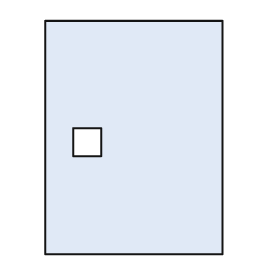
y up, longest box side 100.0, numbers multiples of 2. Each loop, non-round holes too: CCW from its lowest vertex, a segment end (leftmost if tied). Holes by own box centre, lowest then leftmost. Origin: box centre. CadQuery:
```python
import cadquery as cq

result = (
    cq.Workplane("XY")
    .moveTo(-38.0, -50.0)
    .lineTo(38.0, -50.0)
    .lineTo(38.0, 50.0)
    .lineTo(-38.0, 50.0)
    .close()
    .moveTo(-26.0, -8.0)
    .lineTo(-14.0, -8.0)
    .lineTo(-14.0, 4.0)
    .lineTo(-26.0, 4.0)
    .close()
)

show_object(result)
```